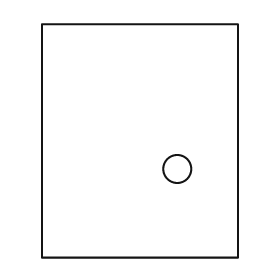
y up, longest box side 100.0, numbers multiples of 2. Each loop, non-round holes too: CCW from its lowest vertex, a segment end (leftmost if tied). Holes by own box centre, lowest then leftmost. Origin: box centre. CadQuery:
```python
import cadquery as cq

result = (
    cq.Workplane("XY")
    .moveTo(-42.0, -50.0)
    .lineTo(42.0, -50.0)
    .lineTo(42.0, 50.0)
    .lineTo(-42.0, 50.0)
    .close()
    .moveTo(16.0, -12.0)
    .circle(6.0)
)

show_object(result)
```